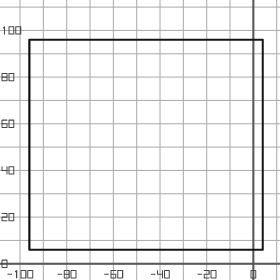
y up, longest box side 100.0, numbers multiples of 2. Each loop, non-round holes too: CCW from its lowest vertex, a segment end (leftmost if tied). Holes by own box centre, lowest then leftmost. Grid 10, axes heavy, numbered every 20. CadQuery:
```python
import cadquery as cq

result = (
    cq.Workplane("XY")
    .moveTo(-96.0, 6.0)
    .lineTo(4.0, 6.0)
    .lineTo(4.0, 96.0)
    .lineTo(-96.0, 96.0)
    .close()
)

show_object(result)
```